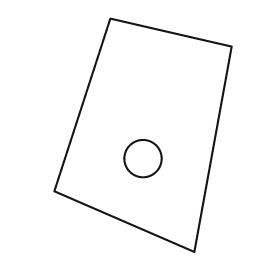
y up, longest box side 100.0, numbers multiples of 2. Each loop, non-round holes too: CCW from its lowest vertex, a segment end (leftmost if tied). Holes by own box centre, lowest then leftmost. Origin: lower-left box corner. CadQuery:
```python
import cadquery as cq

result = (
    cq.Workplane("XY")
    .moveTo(60.0, 0.0)
    .lineTo(76.0, 88.0)
    .lineTo(24.0, 100.0)
    .lineTo(0.0, 26.0)
    .close()
    .moveTo(38.0, 40.0)
    .circle(8.0)
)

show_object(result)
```